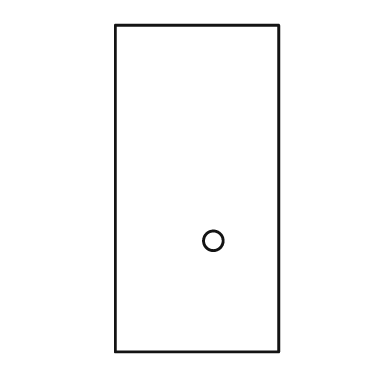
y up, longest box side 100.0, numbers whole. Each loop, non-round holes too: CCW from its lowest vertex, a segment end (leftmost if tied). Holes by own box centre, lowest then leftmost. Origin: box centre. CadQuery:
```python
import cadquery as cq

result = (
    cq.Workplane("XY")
    .moveTo(-25.0, -50.0)
    .lineTo(25.0, -50.0)
    .lineTo(25.0, 50.0)
    .lineTo(-25.0, 50.0)
    .close()
    .moveTo(5.0, -16.0)
    .circle(3.0)
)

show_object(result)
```